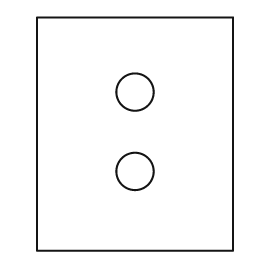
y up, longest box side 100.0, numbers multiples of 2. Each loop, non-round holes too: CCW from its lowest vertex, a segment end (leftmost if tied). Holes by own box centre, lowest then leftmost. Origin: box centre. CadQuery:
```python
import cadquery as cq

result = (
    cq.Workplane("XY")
    .moveTo(-42.0, -50.0)
    .lineTo(42.0, -50.0)
    .lineTo(42.0, 50.0)
    .lineTo(-42.0, 50.0)
    .close()
    .moveTo(0.0, -16.0)
    .circle(8.0)
    .moveTo(0.0, 18.0)
    .circle(8.0)
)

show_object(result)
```